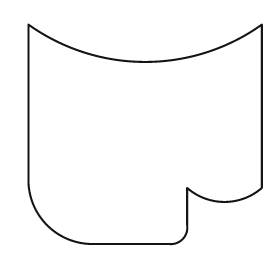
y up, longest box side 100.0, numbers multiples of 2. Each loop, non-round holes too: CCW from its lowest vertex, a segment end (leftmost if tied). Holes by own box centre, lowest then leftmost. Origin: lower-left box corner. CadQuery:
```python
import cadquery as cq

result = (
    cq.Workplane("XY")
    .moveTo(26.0, 0.0)
    .lineTo(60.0, 0.0)
    .threePointArc((66.0, 2.0), (68.0, 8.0))
    .lineTo(68.0, 24.0)
    .threePointArc((84.0, 18.0), (100.0, 24.0))
    .lineTo(100.0, 94.0)
    .threePointArc((50.0, 78.0), (0.0, 94.0))
    .lineTo(0.0, 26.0)
    .threePointArc((8.0, 8.0), (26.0, 0.0))
    .close()
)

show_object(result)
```